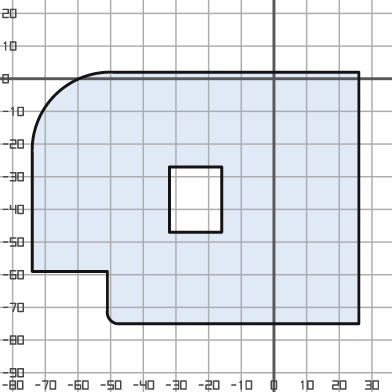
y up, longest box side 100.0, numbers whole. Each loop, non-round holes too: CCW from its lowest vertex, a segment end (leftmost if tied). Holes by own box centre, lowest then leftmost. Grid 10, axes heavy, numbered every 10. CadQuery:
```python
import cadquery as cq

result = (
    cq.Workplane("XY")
    .moveTo(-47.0, -75.0)
    .lineTo(26.0, -75.0)
    .lineTo(26.0, 2.0)
    .lineTo(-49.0, 2.0)
    .threePointArc((-67.0, -5.0), (-74.0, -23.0))
    .lineTo(-74.0, -59.0)
    .lineTo(-51.0, -59.0)
    .lineTo(-51.0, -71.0)
    .threePointArc((-50.0, -74.0), (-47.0, -75.0))
    .close()
    .moveTo(-32.0, -47.0)
    .lineTo(-16.0, -47.0)
    .lineTo(-16.0, -27.0)
    .lineTo(-32.0, -27.0)
    .close()
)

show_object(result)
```